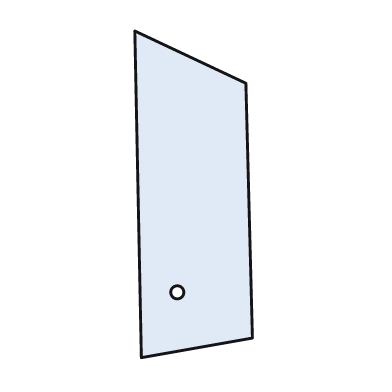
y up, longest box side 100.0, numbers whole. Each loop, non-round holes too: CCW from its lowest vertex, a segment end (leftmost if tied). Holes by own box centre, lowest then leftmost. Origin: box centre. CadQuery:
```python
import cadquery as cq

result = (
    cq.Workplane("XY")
    .moveTo(-16.0, -50.0)
    .lineTo(18.0, -44.0)
    .lineTo(16.0, 34.0)
    .lineTo(-18.0, 50.0)
    .close()
    .moveTo(-5.0, -30.0)
    .circle(2.0)
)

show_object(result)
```